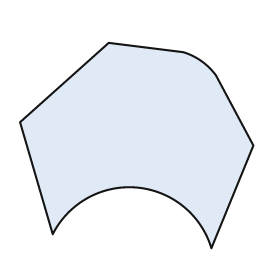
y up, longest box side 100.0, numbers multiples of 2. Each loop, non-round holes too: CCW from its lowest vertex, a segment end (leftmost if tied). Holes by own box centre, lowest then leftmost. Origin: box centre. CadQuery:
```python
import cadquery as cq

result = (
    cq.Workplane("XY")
    .moveTo(32.0, -44.0)
    .lineTo(50.0, 0.0)
    .lineTo(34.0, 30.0)
    .threePointArc((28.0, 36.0), (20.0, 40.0))
    .lineTo(-12.0, 44.0)
    .lineTo(-50.0, 10.0)
    .lineTo(-36.0, -38.0)
    .threePointArc((0.0, -18.0), (32.0, -44.0))
    .close()
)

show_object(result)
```